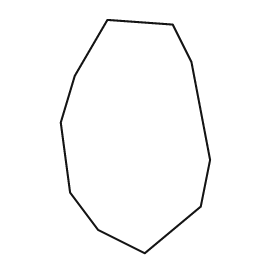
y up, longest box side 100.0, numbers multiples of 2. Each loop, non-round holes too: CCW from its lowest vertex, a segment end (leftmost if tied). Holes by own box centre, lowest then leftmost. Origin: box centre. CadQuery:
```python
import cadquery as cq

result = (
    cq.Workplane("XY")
    .moveTo(4.0, -50.0)
    .lineTo(28.0, -30.0)
    .lineTo(32.0, -10.0)
    .lineTo(24.0, 32.0)
    .lineTo(16.0, 48.0)
    .lineTo(-12.0, 50.0)
    .lineTo(-26.0, 26.0)
    .lineTo(-32.0, 6.0)
    .lineTo(-28.0, -24.0)
    .lineTo(-16.0, -40.0)
    .close()
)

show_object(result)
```